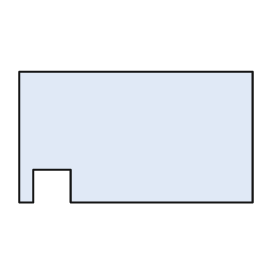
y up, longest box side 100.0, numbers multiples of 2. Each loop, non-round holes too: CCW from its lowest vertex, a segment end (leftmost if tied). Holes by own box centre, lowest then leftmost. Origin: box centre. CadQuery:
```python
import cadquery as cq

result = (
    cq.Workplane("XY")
    .moveTo(-50.0, -28.0)
    .lineTo(-44.0, -28.0)
    .lineTo(-44.0, -14.0)
    .lineTo(-28.0, -14.0)
    .lineTo(-28.0, -28.0)
    .lineTo(50.0, -28.0)
    .lineTo(50.0, 28.0)
    .lineTo(-50.0, 28.0)
    .close()
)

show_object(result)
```